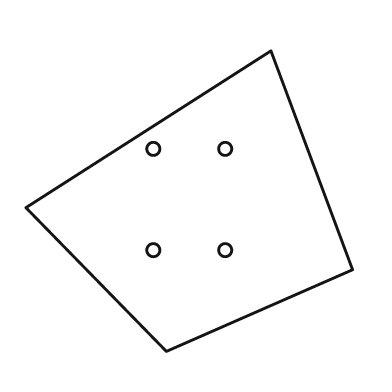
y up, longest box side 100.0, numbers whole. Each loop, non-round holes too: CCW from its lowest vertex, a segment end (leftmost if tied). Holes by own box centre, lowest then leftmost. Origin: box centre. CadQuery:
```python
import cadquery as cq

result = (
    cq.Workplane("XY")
    .moveTo(-7.0, -46.0)
    .lineTo(50.0, -21.0)
    .lineTo(25.0, 46.0)
    .lineTo(-50.0, -2.0)
    .close()
    .moveTo(-11.0, -15.0)
    .circle(2.0)
    .moveTo(11.0, -15.0)
    .circle(2.0)
    .moveTo(-11.0, 16.0)
    .circle(2.0)
    .moveTo(11.0, 16.0)
    .circle(2.0)
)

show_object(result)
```